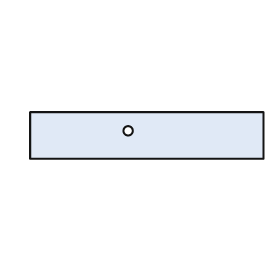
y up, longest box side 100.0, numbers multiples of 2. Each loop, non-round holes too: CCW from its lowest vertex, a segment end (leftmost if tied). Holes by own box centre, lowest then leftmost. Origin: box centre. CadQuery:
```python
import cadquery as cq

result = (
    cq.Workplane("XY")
    .moveTo(-50.0, -10.0)
    .lineTo(50.0, -10.0)
    .lineTo(50.0, 10.0)
    .lineTo(-50.0, 10.0)
    .close()
    .moveTo(-8.0, 2.0)
    .circle(2.0)
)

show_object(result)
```